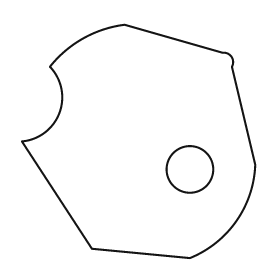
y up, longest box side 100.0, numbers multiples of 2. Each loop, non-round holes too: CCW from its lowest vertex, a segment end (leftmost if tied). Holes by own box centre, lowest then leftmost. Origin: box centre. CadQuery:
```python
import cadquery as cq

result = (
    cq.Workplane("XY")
    .moveTo(22.0, -50.0)
    .threePointArc((42.0, -34.0), (50.0, -10.0))
    .lineTo(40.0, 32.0)
    .threePointArc((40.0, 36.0), (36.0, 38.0))
    .lineTo(-6.0, 50.0)
    .threePointArc((-24.0, 44.0), (-38.0, 32.0))
    .threePointArc((-34.0, 12.0), (-50.0, 0.0))
    .lineTo(-20.0, -46.0)
    .close()
    .moveTo(22.0, -12.0)
    .circle(10.0)
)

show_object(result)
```